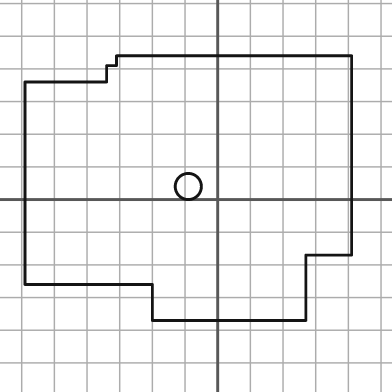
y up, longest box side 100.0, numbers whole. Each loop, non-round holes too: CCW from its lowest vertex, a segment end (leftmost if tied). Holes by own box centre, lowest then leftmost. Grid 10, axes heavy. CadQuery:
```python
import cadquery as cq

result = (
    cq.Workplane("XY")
    .moveTo(-20.0, -37.0)
    .lineTo(27.0, -37.0)
    .lineTo(27.0, -17.0)
    .lineTo(41.0, -17.0)
    .lineTo(41.0, 44.0)
    .lineTo(-31.0, 44.0)
    .lineTo(-31.0, 41.0)
    .lineTo(-34.0, 41.0)
    .lineTo(-34.0, 36.0)
    .lineTo(-59.0, 36.0)
    .lineTo(-59.0, -26.0)
    .lineTo(-20.0, -26.0)
    .close()
    .moveTo(-9.0, 4.0)
    .circle(4.0)
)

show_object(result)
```